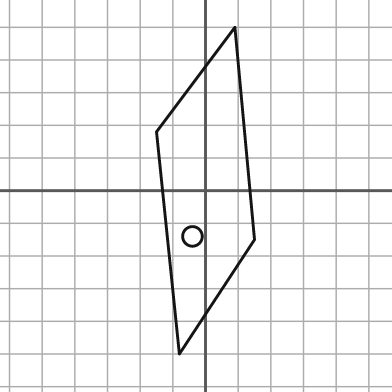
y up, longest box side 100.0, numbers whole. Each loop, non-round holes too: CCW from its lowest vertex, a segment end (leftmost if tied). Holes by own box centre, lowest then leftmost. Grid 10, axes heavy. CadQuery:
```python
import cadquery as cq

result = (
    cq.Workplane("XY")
    .moveTo(-8.0, -50.0)
    .lineTo(15.0, -15.0)
    .lineTo(9.0, 50.0)
    .lineTo(-15.0, 18.0)
    .close()
    .moveTo(-4.0, -14.0)
    .circle(3.0)
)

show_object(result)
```